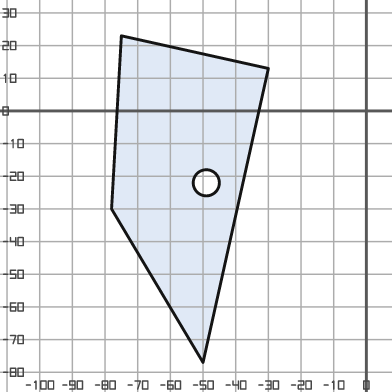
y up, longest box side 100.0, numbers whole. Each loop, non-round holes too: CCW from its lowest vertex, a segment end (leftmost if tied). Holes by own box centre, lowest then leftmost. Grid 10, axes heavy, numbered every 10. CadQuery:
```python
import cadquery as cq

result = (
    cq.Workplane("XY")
    .moveTo(-50.0, -77.0)
    .lineTo(-30.0, 13.0)
    .lineTo(-75.0, 23.0)
    .lineTo(-78.0, -30.0)
    .close()
    .moveTo(-49.0, -22.0)
    .circle(4.0)
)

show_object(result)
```